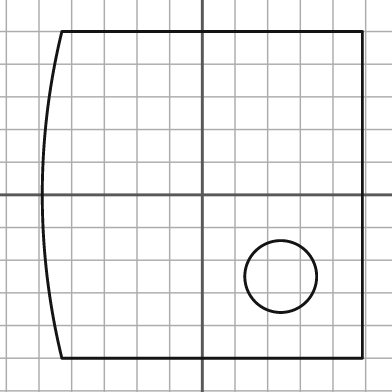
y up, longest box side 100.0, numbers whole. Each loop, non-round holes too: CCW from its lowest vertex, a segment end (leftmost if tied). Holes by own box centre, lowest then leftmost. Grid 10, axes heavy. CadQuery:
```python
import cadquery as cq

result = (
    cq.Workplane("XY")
    .moveTo(-43.0, -50.0)
    .lineTo(49.0, -50.0)
    .lineTo(49.0, 50.0)
    .lineTo(-43.0, 50.0)
    .threePointArc((-49.0, 0.0), (-43.0, -50.0))
    .close()
    .moveTo(24.0, -25.0)
    .circle(11.0)
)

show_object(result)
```